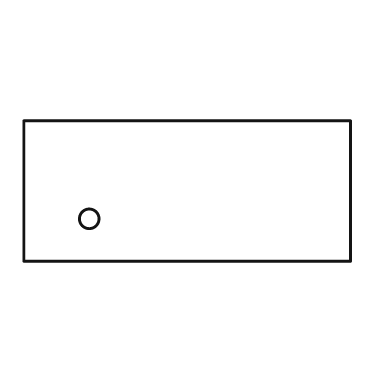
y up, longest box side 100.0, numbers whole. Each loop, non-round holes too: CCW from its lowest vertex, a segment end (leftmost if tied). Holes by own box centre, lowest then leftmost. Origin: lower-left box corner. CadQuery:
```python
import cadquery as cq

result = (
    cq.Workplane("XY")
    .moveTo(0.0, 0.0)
    .lineTo(100.0, 0.0)
    .lineTo(100.0, 43.0)
    .lineTo(0.0, 43.0)
    .close()
    .moveTo(20.0, 13.0)
    .circle(3.0)
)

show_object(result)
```